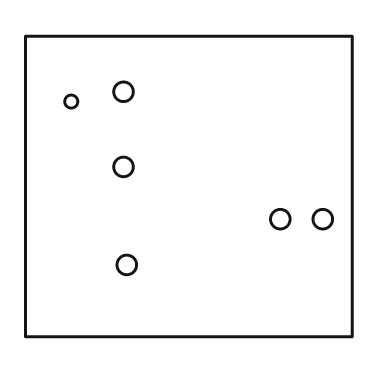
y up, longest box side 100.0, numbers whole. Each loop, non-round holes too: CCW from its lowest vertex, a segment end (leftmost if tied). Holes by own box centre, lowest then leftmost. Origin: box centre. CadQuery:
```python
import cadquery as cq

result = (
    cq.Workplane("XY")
    .moveTo(-50.0, -46.0)
    .lineTo(50.0, -46.0)
    .lineTo(50.0, 46.0)
    .lineTo(-50.0, 46.0)
    .close()
    .moveTo(-19.0, -24.0)
    .circle(3.0)
    .moveTo(28.0, -10.0)
    .circle(3.0)
    .moveTo(41.0, -10.0)
    .circle(3.0)
    .moveTo(-20.0, 6.0)
    .circle(3.0)
    .moveTo(-36.0, 26.0)
    .circle(2.0)
    .moveTo(-20.0, 29.0)
    .circle(3.0)
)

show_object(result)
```